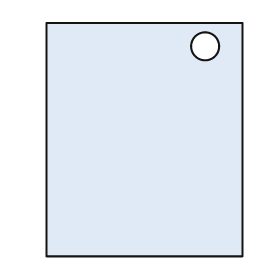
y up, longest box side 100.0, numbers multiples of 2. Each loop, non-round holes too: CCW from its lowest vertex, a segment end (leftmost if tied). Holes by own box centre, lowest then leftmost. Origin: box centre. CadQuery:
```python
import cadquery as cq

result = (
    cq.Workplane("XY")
    .moveTo(-42.0, -50.0)
    .lineTo(42.0, -50.0)
    .lineTo(42.0, 50.0)
    .lineTo(-42.0, 50.0)
    .close()
    .moveTo(26.0, 40.0)
    .circle(6.0)
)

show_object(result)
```